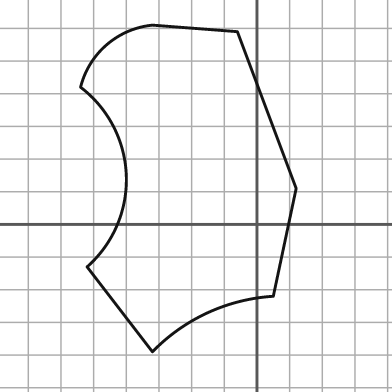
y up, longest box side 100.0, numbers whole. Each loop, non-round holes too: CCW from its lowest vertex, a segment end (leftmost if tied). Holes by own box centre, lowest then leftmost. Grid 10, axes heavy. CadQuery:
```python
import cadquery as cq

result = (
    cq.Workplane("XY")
    .moveTo(-32.0, -39.0)
    .threePointArc((-15.0, -27.0), (5.0, -22.0))
    .lineTo(12.0, 11.0)
    .lineTo(-6.0, 59.0)
    .lineTo(-32.0, 61.0)
    .threePointArc((-46.0, 55.0), (-54.0, 42.0))
    .threePointArc((-40.0, 15.0), (-52.0, -13.0))
    .close()
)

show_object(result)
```